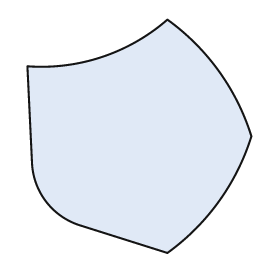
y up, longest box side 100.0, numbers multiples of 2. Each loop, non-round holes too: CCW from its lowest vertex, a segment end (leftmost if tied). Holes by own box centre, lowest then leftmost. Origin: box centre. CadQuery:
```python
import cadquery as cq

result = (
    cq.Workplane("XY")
    .moveTo(12.0, -50.0)
    .threePointArc((34.0, -28.0), (48.0, 0.0))
    .threePointArc((34.0, 28.0), (12.0, 50.0))
    .threePointArc((-16.0, 34.0), (-48.0, 30.0))
    .lineTo(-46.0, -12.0)
    .threePointArc((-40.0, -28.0), (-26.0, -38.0))
    .close()
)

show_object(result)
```